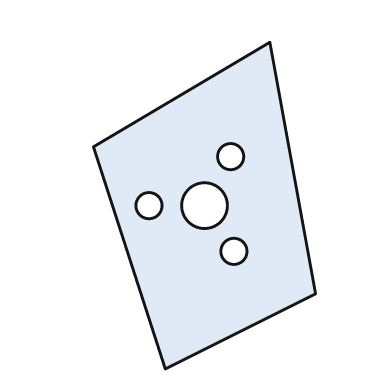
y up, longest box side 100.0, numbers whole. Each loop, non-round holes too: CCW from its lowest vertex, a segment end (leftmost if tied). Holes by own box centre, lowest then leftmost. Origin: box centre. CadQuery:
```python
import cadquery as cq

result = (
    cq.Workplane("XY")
    .moveTo(-12.0, -50.0)
    .lineTo(34.0, -27.0)
    .lineTo(20.0, 50.0)
    .lineTo(-34.0, 18.0)
    .close()
    .moveTo(9.0, -14.0)
    .circle(4.0)
    .moveTo(-17.0, 0.0)
    .circle(4.0)
    .moveTo(0.0, 0.0)
    .circle(7.0)
    .moveTo(8.0, 15.0)
    .circle(4.0)
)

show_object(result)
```